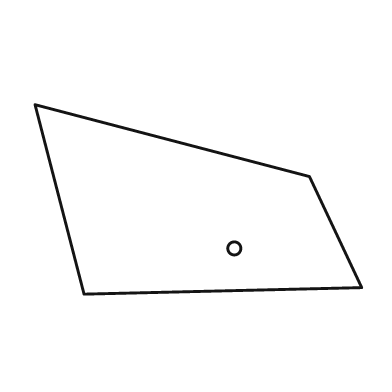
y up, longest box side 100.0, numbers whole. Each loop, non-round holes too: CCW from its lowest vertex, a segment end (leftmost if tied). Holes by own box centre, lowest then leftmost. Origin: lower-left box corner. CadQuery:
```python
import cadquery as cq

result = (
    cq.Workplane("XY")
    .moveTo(15.0, 0.0)
    .lineTo(100.0, 2.0)
    .lineTo(84.0, 36.0)
    .lineTo(0.0, 58.0)
    .close()
    .moveTo(61.0, 14.0)
    .circle(2.0)
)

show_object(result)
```